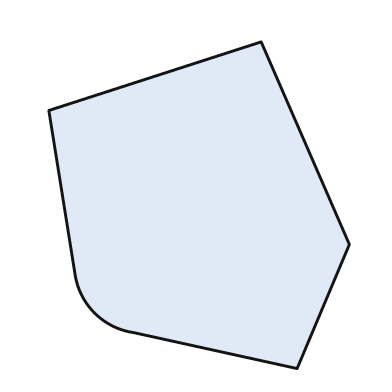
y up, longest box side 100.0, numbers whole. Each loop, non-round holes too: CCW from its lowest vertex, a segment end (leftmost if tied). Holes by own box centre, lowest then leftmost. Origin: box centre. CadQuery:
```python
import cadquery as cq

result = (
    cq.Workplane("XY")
    .moveTo(30.0, -50.0)
    .lineTo(46.0, -12.0)
    .lineTo(19.0, 50.0)
    .lineTo(-46.0, 29.0)
    .lineTo(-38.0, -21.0)
    .threePointArc((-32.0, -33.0), (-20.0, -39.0))
    .close()
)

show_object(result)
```